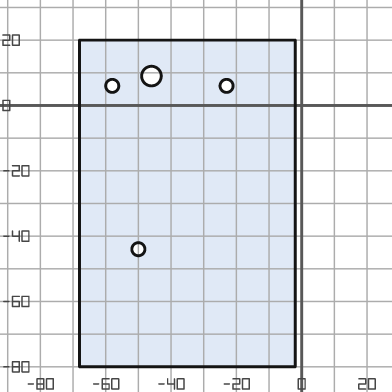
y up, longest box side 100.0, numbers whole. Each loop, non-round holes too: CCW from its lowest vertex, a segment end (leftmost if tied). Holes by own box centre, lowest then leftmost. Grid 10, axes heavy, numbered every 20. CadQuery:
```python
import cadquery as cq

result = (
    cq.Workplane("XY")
    .moveTo(-68.0, -80.0)
    .lineTo(-2.0, -80.0)
    .lineTo(-2.0, 20.0)
    .lineTo(-68.0, 20.0)
    .close()
    .moveTo(-50.0, -44.0)
    .circle(2.0)
    .moveTo(-58.0, 6.0)
    .circle(2.0)
    .moveTo(-23.0, 6.0)
    .circle(2.0)
    .moveTo(-46.0, 9.0)
    .circle(3.0)
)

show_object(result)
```